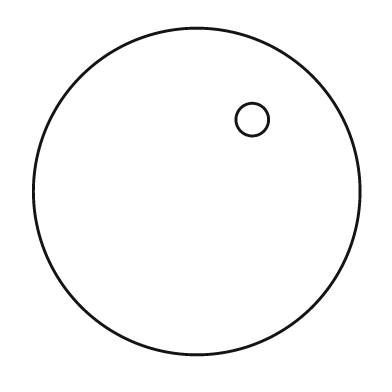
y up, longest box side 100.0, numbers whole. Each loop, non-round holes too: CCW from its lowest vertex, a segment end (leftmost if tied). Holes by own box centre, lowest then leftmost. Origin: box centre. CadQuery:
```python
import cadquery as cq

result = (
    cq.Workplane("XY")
    .moveTo(0.0, 0.0)
    .circle(50.0)
    .moveTo(17.0, 22.0)
    .circle(5.0)
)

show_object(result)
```